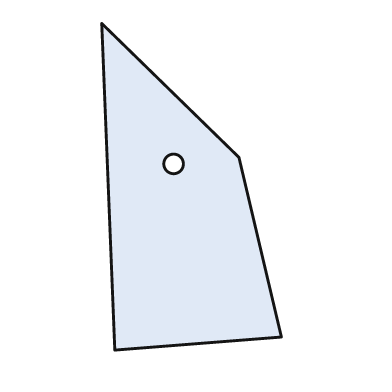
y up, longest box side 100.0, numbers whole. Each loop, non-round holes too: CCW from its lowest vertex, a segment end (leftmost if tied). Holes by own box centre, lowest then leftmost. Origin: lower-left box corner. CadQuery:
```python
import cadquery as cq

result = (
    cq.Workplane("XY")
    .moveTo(4.0, 0.0)
    .lineTo(55.0, 4.0)
    .lineTo(42.0, 59.0)
    .lineTo(0.0, 100.0)
    .close()
    .moveTo(22.0, 57.0)
    .circle(3.0)
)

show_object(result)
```